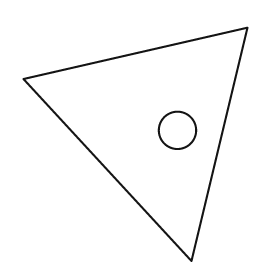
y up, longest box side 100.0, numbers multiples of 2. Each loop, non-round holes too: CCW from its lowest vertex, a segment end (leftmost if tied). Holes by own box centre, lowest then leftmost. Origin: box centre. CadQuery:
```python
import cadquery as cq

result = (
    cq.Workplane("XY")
    .moveTo(24.0, -50.0)
    .lineTo(48.0, 50.0)
    .lineTo(-48.0, 28.0)
    .close()
    .moveTo(18.0, 6.0)
    .circle(8.0)
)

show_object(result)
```